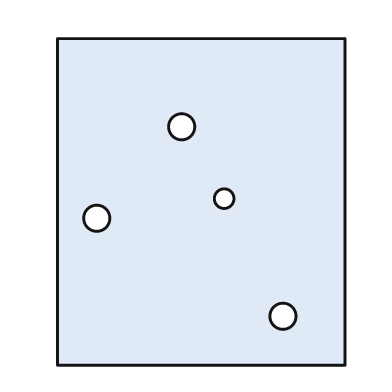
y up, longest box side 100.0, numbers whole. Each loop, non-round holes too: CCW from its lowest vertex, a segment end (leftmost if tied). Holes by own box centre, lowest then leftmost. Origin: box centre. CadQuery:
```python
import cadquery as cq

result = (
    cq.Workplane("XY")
    .moveTo(-44.0, -50.0)
    .lineTo(44.0, -50.0)
    .lineTo(44.0, 50.0)
    .lineTo(-44.0, 50.0)
    .close()
    .moveTo(25.0, -35.0)
    .circle(4.0)
    .moveTo(-32.0, -5.0)
    .circle(4.0)
    .moveTo(7.0, 1.0)
    .circle(3.0)
    .moveTo(-6.0, 23.0)
    .circle(4.0)
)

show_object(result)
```